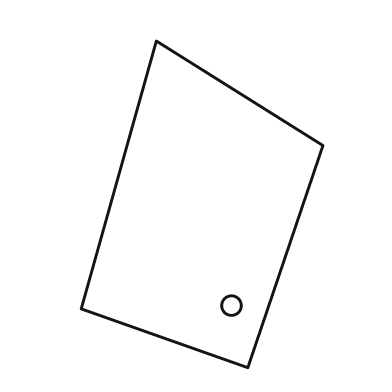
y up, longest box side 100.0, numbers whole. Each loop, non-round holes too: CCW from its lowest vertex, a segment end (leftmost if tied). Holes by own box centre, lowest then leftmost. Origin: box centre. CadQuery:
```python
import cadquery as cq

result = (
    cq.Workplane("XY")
    .moveTo(14.0, -50.0)
    .lineTo(37.0, 18.0)
    .lineTo(-14.0, 50.0)
    .lineTo(-37.0, -32.0)
    .close()
    .moveTo(9.0, -31.0)
    .circle(3.0)
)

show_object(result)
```